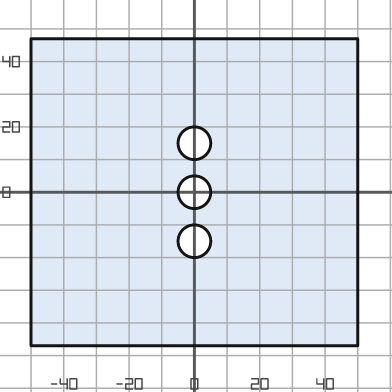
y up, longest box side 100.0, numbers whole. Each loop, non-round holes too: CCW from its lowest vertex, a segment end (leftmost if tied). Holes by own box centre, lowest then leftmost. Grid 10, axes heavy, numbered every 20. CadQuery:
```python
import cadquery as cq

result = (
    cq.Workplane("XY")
    .moveTo(-50.0, -47.0)
    .lineTo(50.0, -47.0)
    .lineTo(50.0, 47.0)
    .lineTo(-50.0, 47.0)
    .close()
    .moveTo(0.0, -15.0)
    .circle(5.0)
    .moveTo(0.0, 0.0)
    .circle(5.0)
    .moveTo(0.0, 15.0)
    .circle(5.0)
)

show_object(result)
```